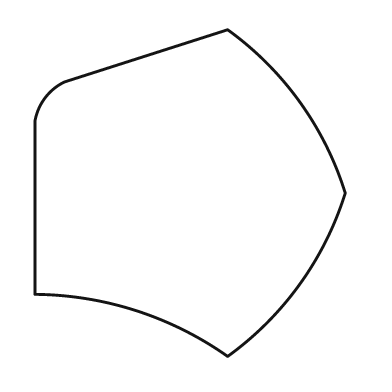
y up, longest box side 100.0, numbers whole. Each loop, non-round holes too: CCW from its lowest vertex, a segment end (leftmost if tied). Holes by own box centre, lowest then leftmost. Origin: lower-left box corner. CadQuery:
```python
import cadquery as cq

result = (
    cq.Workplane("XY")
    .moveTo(59.0, 0.0)
    .threePointArc((81.0, 22.0), (95.0, 50.0))
    .threePointArc((81.0, 78.0), (59.0, 100.0))
    .lineTo(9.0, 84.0)
    .threePointArc((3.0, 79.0), (0.0, 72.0))
    .lineTo(0.0, 19.0)
    .threePointArc((31.0, 14.0), (59.0, 0.0))
    .close()
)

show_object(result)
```